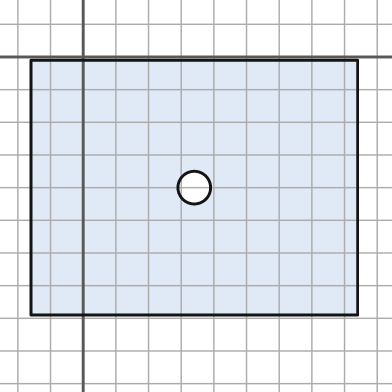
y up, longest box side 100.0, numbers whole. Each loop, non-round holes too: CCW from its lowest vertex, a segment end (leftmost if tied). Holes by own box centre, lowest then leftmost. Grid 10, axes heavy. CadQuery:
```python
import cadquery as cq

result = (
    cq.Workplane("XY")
    .moveTo(-16.0, -79.0)
    .lineTo(84.0, -79.0)
    .lineTo(84.0, -1.0)
    .lineTo(-16.0, -1.0)
    .close()
    .moveTo(34.0, -40.0)
    .circle(5.0)
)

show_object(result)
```